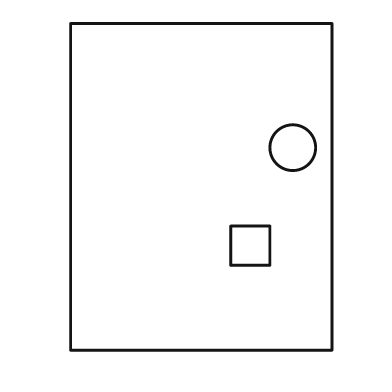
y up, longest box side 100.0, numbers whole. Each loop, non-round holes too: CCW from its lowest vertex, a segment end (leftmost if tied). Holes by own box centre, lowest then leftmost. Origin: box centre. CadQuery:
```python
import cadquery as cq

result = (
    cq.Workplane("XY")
    .moveTo(-40.0, -50.0)
    .lineTo(40.0, -50.0)
    .lineTo(40.0, 50.0)
    .lineTo(-40.0, 50.0)
    .close()
    .moveTo(9.0, -24.0)
    .lineTo(21.0, -24.0)
    .lineTo(21.0, -12.0)
    .lineTo(9.0, -12.0)
    .close()
    .moveTo(28.0, 12.0)
    .circle(7.0)
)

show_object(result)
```